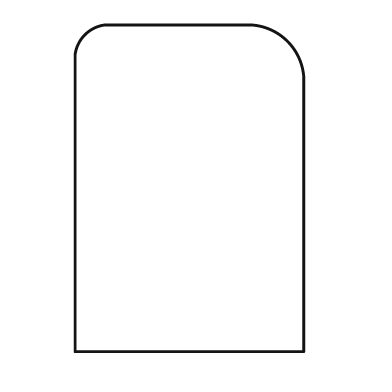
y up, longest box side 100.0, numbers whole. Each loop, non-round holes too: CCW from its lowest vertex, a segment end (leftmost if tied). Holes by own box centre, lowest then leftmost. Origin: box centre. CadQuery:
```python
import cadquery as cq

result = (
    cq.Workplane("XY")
    .moveTo(-35.0, -50.0)
    .lineTo(35.0, -50.0)
    .lineTo(35.0, 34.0)
    .threePointArc((30.0, 45.0), (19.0, 50.0))
    .lineTo(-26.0, 50.0)
    .threePointArc((-32.0, 47.0), (-35.0, 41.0))
    .close()
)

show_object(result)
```